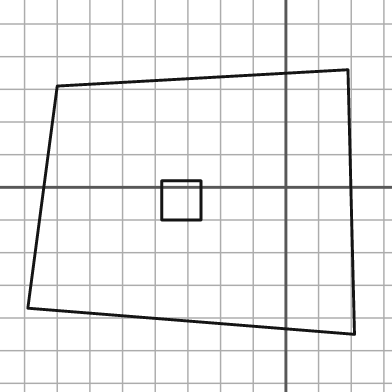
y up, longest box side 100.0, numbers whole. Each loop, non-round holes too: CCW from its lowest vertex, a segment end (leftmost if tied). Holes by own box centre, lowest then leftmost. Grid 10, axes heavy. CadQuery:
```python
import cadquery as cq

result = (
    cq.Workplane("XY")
    .moveTo(21.0, -45.0)
    .lineTo(19.0, 36.0)
    .lineTo(-70.0, 31.0)
    .lineTo(-79.0, -37.0)
    .close()
    .moveTo(-38.0, -10.0)
    .lineTo(-26.0, -10.0)
    .lineTo(-26.0, 2.0)
    .lineTo(-38.0, 2.0)
    .close()
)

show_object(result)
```